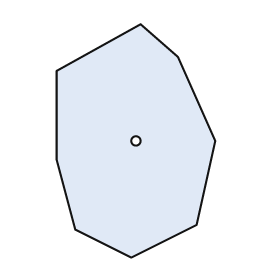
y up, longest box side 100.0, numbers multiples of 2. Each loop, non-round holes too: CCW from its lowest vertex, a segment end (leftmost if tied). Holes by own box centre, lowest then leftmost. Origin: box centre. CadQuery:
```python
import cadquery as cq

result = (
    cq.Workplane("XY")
    .moveTo(-2.0, -50.0)
    .lineTo(26.0, -36.0)
    .lineTo(34.0, 0.0)
    .lineTo(18.0, 36.0)
    .lineTo(2.0, 50.0)
    .lineTo(-34.0, 30.0)
    .lineTo(-34.0, -8.0)
    .lineTo(-26.0, -38.0)
    .close()
    .moveTo(0.0, 0.0)
    .circle(2.0)
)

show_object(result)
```